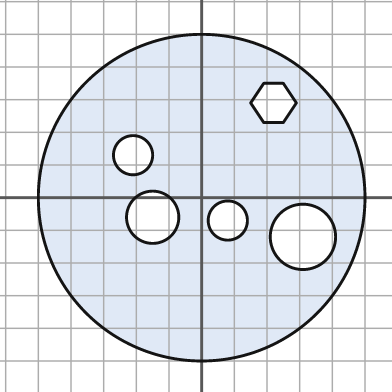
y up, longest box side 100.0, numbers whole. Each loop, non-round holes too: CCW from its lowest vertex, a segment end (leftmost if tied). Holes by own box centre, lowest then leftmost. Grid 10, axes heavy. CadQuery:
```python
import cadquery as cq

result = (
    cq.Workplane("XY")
    .moveTo(0.0, 0.0)
    .circle(50.0)
    .moveTo(31.0, -12.0)
    .circle(10.0)
    .moveTo(8.0, -7.0)
    .circle(6.0)
    .moveTo(-15.0, -6.0)
    .circle(8.0)
    .moveTo(-21.0, 13.0)
    .circle(6.0)
    .moveTo(19.0, 23.0)
    .lineTo(25.0, 23.0)
    .lineTo(29.0, 29.0)
    .lineTo(25.0, 35.0)
    .lineTo(19.0, 35.0)
    .lineTo(15.0, 29.0)
    .close()
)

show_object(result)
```